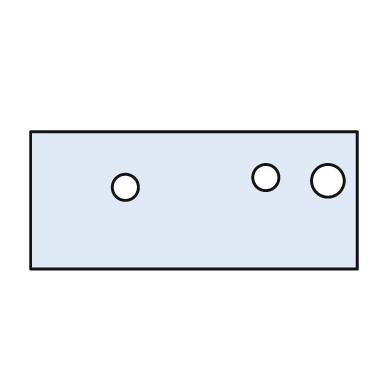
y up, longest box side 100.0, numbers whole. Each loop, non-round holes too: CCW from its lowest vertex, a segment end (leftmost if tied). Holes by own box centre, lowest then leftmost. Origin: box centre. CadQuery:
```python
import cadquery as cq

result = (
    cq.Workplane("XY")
    .moveTo(-50.0, -21.0)
    .lineTo(50.0, -21.0)
    .lineTo(50.0, 21.0)
    .lineTo(-50.0, 21.0)
    .close()
    .moveTo(-21.0, 4.0)
    .circle(4.0)
    .moveTo(41.0, 6.0)
    .circle(5.0)
    .moveTo(22.0, 7.0)
    .circle(4.0)
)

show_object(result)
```